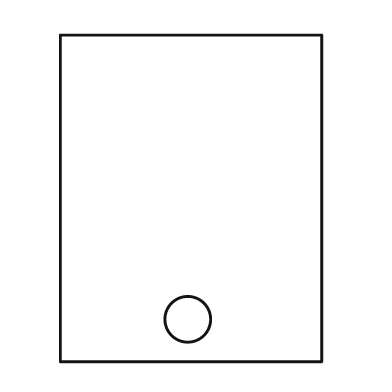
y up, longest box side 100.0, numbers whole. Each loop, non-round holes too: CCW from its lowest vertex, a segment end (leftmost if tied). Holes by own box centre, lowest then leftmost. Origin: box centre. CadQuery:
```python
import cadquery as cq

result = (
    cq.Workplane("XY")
    .moveTo(-40.0, -50.0)
    .lineTo(40.0, -50.0)
    .lineTo(40.0, 50.0)
    .lineTo(-40.0, 50.0)
    .close()
    .moveTo(-1.0, -37.0)
    .circle(7.0)
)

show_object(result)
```